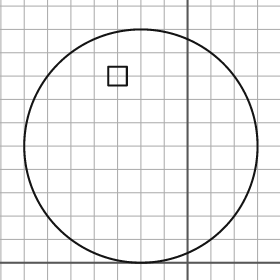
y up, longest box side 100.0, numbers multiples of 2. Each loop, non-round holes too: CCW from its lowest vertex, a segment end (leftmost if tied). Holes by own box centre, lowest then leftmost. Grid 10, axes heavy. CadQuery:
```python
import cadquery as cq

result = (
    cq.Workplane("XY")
    .moveTo(-20.0, 50.0)
    .circle(50.0)
    .moveTo(-34.0, 76.0)
    .lineTo(-26.0, 76.0)
    .lineTo(-26.0, 84.0)
    .lineTo(-34.0, 84.0)
    .close()
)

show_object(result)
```